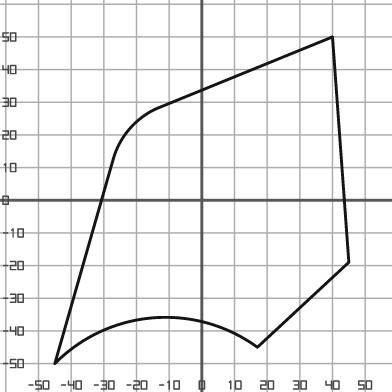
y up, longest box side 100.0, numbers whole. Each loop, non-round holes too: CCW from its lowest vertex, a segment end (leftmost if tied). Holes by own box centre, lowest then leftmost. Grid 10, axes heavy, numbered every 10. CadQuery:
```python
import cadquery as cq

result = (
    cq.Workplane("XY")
    .moveTo(-45.0, -50.0)
    .threePointArc((-15.0, -36.0), (17.0, -45.0))
    .lineTo(45.0, -19.0)
    .lineTo(40.0, 50.0)
    .lineTo(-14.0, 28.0)
    .threePointArc((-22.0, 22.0), (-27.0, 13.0))
    .close()
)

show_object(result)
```